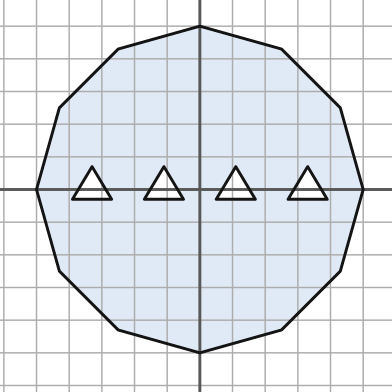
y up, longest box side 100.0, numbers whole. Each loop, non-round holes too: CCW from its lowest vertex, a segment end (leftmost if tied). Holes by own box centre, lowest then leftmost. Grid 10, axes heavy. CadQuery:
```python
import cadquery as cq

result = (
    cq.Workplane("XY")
    .moveTo(0.0, -50.0)
    .lineTo(25.0, -43.0)
    .lineTo(43.0, -25.0)
    .lineTo(50.0, 0.0)
    .lineTo(43.0, 25.0)
    .lineTo(25.0, 43.0)
    .lineTo(0.0, 50.0)
    .lineTo(-25.0, 43.0)
    .lineTo(-43.0, 25.0)
    .lineTo(-50.0, 0.0)
    .lineTo(-43.0, -25.0)
    .lineTo(-25.0, -43.0)
    .close()
    .moveTo(-39.0, -3.0)
    .lineTo(-27.0, -3.0)
    .lineTo(-33.0, 7.0)
    .close()
    .moveTo(-17.0, -3.0)
    .lineTo(-5.0, -3.0)
    .lineTo(-11.0, 7.0)
    .close()
    .moveTo(5.0, -3.0)
    .lineTo(17.0, -3.0)
    .lineTo(11.0, 7.0)
    .close()
    .moveTo(27.0, -3.0)
    .lineTo(39.0, -3.0)
    .lineTo(33.0, 7.0)
    .close()
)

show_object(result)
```